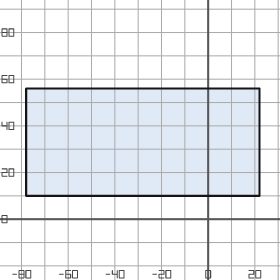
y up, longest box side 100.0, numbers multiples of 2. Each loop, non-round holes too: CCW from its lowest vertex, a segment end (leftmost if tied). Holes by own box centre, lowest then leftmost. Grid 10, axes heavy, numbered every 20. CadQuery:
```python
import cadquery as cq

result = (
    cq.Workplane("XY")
    .moveTo(-78.0, 10.0)
    .lineTo(22.0, 10.0)
    .lineTo(22.0, 56.0)
    .lineTo(-78.0, 56.0)
    .close()
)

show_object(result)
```